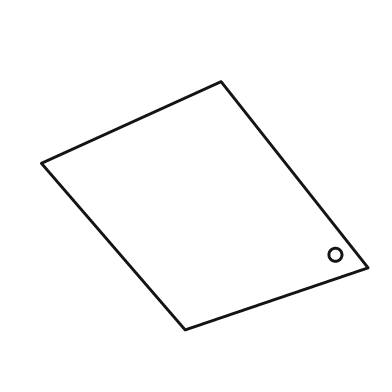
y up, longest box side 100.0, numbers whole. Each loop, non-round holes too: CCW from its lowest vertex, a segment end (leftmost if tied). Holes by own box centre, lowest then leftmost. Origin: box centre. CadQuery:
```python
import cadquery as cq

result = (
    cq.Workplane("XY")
    .moveTo(-6.0, -38.0)
    .lineTo(50.0, -19.0)
    .lineTo(5.0, 38.0)
    .lineTo(-50.0, 13.0)
    .close()
    .moveTo(40.0, -15.0)
    .circle(2.0)
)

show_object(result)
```